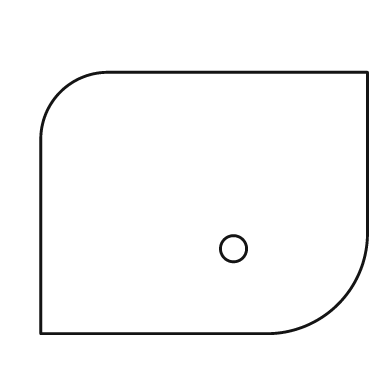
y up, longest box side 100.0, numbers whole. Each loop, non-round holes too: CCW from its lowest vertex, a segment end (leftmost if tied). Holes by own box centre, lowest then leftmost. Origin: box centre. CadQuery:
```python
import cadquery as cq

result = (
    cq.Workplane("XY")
    .moveTo(-50.0, -40.0)
    .lineTo(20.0, -40.0)
    .threePointArc((41.0, -31.0), (50.0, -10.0))
    .lineTo(50.0, 40.0)
    .lineTo(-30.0, 40.0)
    .threePointArc((-44.0, 34.0), (-50.0, 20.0))
    .close()
    .moveTo(9.0, -14.0)
    .circle(4.0)
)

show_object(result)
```